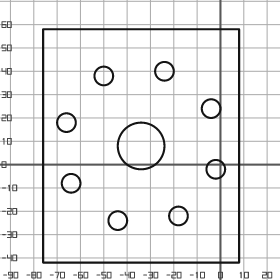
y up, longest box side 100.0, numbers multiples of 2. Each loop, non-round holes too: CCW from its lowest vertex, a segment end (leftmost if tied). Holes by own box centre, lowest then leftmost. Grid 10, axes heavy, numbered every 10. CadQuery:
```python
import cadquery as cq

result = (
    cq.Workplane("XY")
    .moveTo(-76.0, -42.0)
    .lineTo(8.0, -42.0)
    .lineTo(8.0, 58.0)
    .lineTo(-76.0, 58.0)
    .close()
    .moveTo(-44.0, -24.0)
    .circle(4.0)
    .moveTo(-18.0, -22.0)
    .circle(4.0)
    .moveTo(-64.0, -8.0)
    .circle(4.0)
    .moveTo(-2.0, -2.0)
    .circle(4.0)
    .moveTo(-34.0, 8.0)
    .circle(10.0)
    .moveTo(-66.0, 18.0)
    .circle(4.0)
    .moveTo(-4.0, 24.0)
    .circle(4.0)
    .moveTo(-50.0, 38.0)
    .circle(4.0)
    .moveTo(-24.0, 40.0)
    .circle(4.0)
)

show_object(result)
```